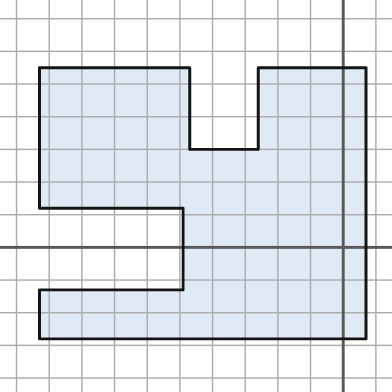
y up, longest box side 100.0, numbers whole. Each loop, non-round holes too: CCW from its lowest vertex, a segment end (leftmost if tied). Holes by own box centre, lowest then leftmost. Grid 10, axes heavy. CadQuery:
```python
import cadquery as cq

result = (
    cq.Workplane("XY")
    .moveTo(-93.0, -28.0)
    .lineTo(7.0, -28.0)
    .lineTo(7.0, 55.0)
    .lineTo(-26.0, 55.0)
    .lineTo(-26.0, 30.0)
    .lineTo(-47.0, 30.0)
    .lineTo(-47.0, 55.0)
    .lineTo(-93.0, 55.0)
    .lineTo(-93.0, 12.0)
    .lineTo(-49.0, 12.0)
    .lineTo(-49.0, -13.0)
    .lineTo(-93.0, -13.0)
    .close()
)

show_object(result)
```